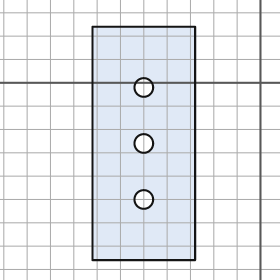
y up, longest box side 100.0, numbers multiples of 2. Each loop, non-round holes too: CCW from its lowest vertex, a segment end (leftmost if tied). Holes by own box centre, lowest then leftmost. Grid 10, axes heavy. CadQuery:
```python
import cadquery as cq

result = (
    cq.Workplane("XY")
    .moveTo(-72.0, -76.0)
    .lineTo(-28.0, -76.0)
    .lineTo(-28.0, 24.0)
    .lineTo(-72.0, 24.0)
    .close()
    .moveTo(-50.0, -50.0)
    .circle(4.0)
    .moveTo(-50.0, -26.0)
    .circle(4.0)
    .moveTo(-50.0, -2.0)
    .circle(4.0)
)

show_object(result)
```